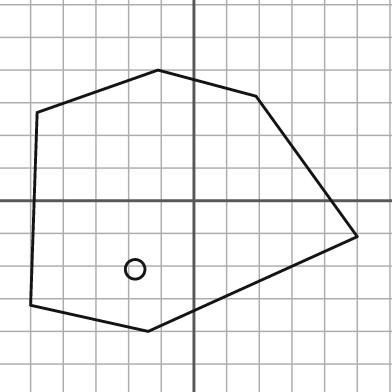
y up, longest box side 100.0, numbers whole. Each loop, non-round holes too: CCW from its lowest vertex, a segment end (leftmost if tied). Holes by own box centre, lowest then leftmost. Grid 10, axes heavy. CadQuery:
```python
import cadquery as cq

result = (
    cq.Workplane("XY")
    .moveTo(-14.0, -40.0)
    .lineTo(50.0, -11.0)
    .lineTo(19.0, 32.0)
    .lineTo(-11.0, 40.0)
    .lineTo(-48.0, 27.0)
    .lineTo(-50.0, -32.0)
    .close()
    .moveTo(-18.0, -21.0)
    .circle(3.0)
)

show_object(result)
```